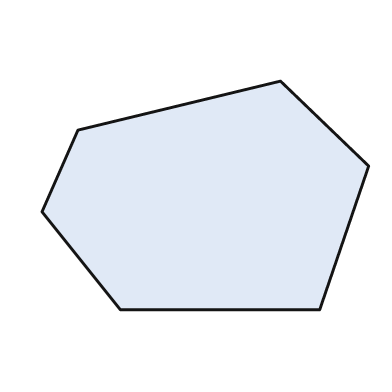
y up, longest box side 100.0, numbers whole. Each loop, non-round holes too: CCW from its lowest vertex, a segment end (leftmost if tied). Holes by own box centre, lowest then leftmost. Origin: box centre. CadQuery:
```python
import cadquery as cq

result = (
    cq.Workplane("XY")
    .moveTo(-26.0, -35.0)
    .lineTo(35.0, -35.0)
    .lineTo(50.0, 9.0)
    .lineTo(23.0, 35.0)
    .lineTo(-39.0, 20.0)
    .lineTo(-50.0, -5.0)
    .close()
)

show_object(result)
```